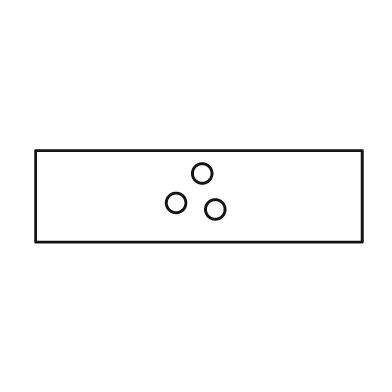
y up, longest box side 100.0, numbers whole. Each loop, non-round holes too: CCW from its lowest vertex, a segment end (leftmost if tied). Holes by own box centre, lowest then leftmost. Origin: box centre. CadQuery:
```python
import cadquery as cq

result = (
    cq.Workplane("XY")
    .moveTo(-50.0, -14.0)
    .lineTo(50.0, -14.0)
    .lineTo(50.0, 14.0)
    .lineTo(-50.0, 14.0)
    .close()
    .moveTo(5.0, -4.0)
    .circle(3.0)
    .moveTo(-7.0, -2.0)
    .circle(3.0)
    .moveTo(1.0, 7.0)
    .circle(3.0)
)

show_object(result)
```